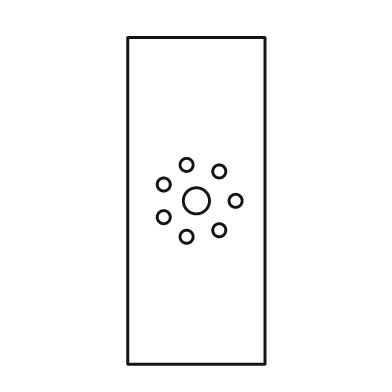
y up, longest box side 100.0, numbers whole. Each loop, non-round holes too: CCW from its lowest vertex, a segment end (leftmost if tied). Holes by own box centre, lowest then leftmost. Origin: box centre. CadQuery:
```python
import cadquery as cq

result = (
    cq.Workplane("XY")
    .moveTo(-21.0, -50.0)
    .lineTo(21.0, -50.0)
    .lineTo(21.0, 50.0)
    .lineTo(-21.0, 50.0)
    .close()
    .moveTo(-3.0, -11.0)
    .circle(2.0)
    .moveTo(7.0, -9.0)
    .circle(2.0)
    .moveTo(-10.0, -5.0)
    .circle(2.0)
    .moveTo(0.0, 0.0)
    .circle(4.0)
    .moveTo(12.0, 0.0)
    .circle(2.0)
    .moveTo(-10.0, 5.0)
    .circle(2.0)
    .moveTo(7.0, 9.0)
    .circle(2.0)
    .moveTo(-3.0, 11.0)
    .circle(2.0)
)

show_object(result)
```